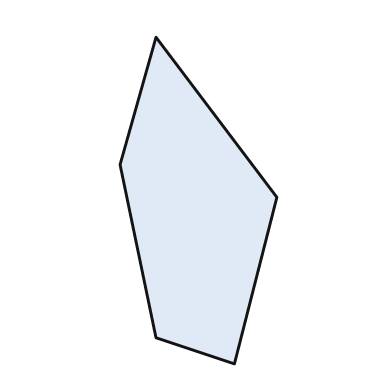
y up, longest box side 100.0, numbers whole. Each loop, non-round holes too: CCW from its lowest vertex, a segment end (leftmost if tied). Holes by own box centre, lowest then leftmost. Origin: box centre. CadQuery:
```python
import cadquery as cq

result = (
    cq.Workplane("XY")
    .moveTo(11.0, -50.0)
    .lineTo(24.0, 1.0)
    .lineTo(-13.0, 50.0)
    .lineTo(-24.0, 11.0)
    .lineTo(-13.0, -42.0)
    .close()
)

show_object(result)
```